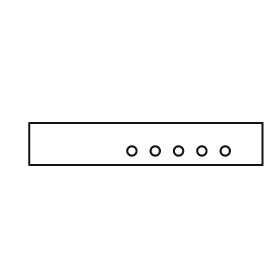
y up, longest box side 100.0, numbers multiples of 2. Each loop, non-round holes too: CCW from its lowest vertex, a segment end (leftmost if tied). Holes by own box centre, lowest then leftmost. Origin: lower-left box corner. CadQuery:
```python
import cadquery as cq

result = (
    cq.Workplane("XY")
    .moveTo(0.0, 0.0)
    .lineTo(100.0, 0.0)
    .lineTo(100.0, 18.0)
    .lineTo(0.0, 18.0)
    .close()
    .moveTo(44.0, 6.0)
    .circle(2.0)
    .moveTo(54.0, 6.0)
    .circle(2.0)
    .moveTo(64.0, 6.0)
    .circle(2.0)
    .moveTo(74.0, 6.0)
    .circle(2.0)
    .moveTo(84.0, 6.0)
    .circle(2.0)
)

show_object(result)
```